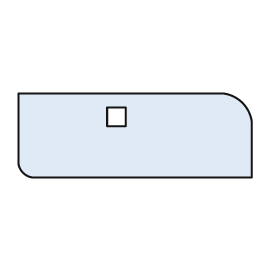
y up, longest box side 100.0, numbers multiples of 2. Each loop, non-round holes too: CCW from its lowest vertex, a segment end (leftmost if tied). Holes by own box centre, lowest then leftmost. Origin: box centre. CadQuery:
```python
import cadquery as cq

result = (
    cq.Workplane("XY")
    .moveTo(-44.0, -18.0)
    .lineTo(50.0, -18.0)
    .lineTo(50.0, 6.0)
    .threePointArc((46.0, 14.0), (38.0, 18.0))
    .lineTo(-50.0, 18.0)
    .lineTo(-50.0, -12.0)
    .threePointArc((-48.0, -16.0), (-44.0, -18.0))
    .close()
    .moveTo(-12.0, 4.0)
    .lineTo(-4.0, 4.0)
    .lineTo(-4.0, 12.0)
    .lineTo(-12.0, 12.0)
    .close()
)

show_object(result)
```